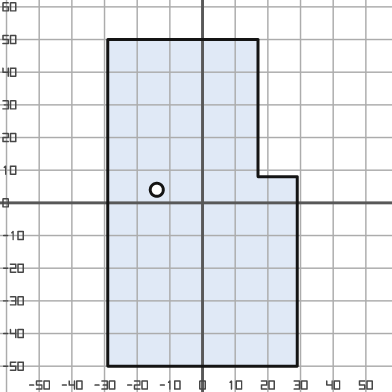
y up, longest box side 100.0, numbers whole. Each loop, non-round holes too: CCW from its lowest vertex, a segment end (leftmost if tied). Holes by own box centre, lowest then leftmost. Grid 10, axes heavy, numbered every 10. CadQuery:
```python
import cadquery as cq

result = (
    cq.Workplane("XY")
    .moveTo(-29.0, -50.0)
    .lineTo(29.0, -50.0)
    .lineTo(29.0, 8.0)
    .lineTo(17.0, 8.0)
    .lineTo(17.0, 50.0)
    .lineTo(-29.0, 50.0)
    .close()
    .moveTo(-14.0, 4.0)
    .circle(2.0)
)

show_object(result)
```